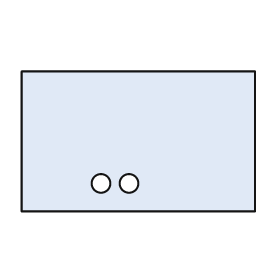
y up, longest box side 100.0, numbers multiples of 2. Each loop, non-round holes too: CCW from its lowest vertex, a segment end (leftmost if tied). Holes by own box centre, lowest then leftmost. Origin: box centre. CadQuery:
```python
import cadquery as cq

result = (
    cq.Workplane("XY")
    .moveTo(-50.0, -30.0)
    .lineTo(50.0, -30.0)
    .lineTo(50.0, 30.0)
    .lineTo(-50.0, 30.0)
    .close()
    .moveTo(-16.0, -18.0)
    .circle(4.0)
    .moveTo(-4.0, -18.0)
    .circle(4.0)
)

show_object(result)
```